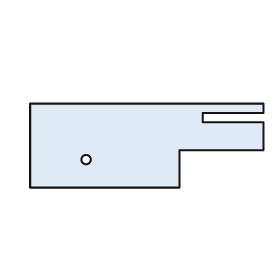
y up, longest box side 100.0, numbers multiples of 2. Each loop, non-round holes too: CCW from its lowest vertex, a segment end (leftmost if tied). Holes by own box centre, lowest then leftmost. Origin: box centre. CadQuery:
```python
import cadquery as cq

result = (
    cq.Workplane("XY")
    .moveTo(-50.0, -18.0)
    .lineTo(14.0, -18.0)
    .lineTo(14.0, -2.0)
    .lineTo(50.0, -2.0)
    .lineTo(50.0, 10.0)
    .lineTo(24.0, 10.0)
    .lineTo(24.0, 14.0)
    .lineTo(50.0, 14.0)
    .lineTo(50.0, 18.0)
    .lineTo(-50.0, 18.0)
    .close()
    .moveTo(-26.0, -6.0)
    .circle(2.0)
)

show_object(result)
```